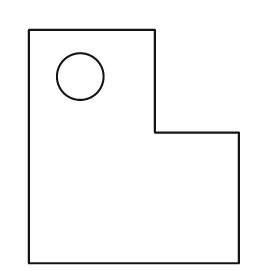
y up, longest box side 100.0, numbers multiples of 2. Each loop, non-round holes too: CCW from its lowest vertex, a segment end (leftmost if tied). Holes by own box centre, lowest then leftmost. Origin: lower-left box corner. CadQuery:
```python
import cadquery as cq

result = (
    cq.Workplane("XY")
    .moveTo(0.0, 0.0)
    .lineTo(90.0, 0.0)
    .lineTo(90.0, 56.0)
    .lineTo(54.0, 56.0)
    .lineTo(54.0, 100.0)
    .lineTo(0.0, 100.0)
    .close()
    .moveTo(22.0, 80.0)
    .circle(10.0)
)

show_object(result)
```